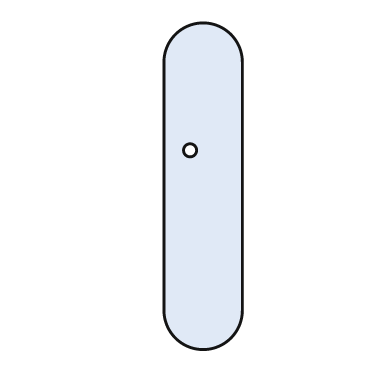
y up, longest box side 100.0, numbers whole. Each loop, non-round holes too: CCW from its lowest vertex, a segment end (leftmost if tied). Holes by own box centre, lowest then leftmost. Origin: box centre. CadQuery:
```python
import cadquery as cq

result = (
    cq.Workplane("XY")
    .moveTo(-12.0, -38.0)
    .threePointArc((0.0, -50.0), (12.0, -38.0))
    .lineTo(12.0, 38.0)
    .threePointArc((0.0, 50.0), (-12.0, 38.0))
    .close()
    .moveTo(-4.0, 11.0)
    .circle(2.0)
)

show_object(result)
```